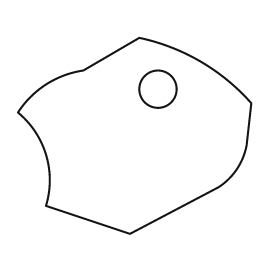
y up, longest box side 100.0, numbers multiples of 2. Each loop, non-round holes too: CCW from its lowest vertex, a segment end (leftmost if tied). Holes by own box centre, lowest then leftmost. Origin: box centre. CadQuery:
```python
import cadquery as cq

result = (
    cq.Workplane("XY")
    .moveTo(-2.0, -42.0)
    .lineTo(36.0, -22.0)
    .threePointArc((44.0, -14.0), (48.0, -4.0))
    .lineTo(50.0, 14.0)
    .threePointArc((28.0, 32.0), (2.0, 42.0))
    .lineTo(-22.0, 28.0)
    .threePointArc((-38.0, 22.0), (-50.0, 10.0))
    .threePointArc((-38.0, -8.0), (-38.0, -30.0))
    .close()
    .moveTo(10.0, 20.0)
    .circle(8.0)
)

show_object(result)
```